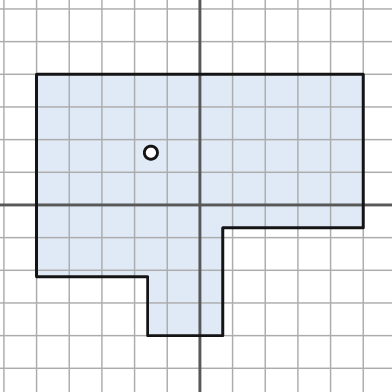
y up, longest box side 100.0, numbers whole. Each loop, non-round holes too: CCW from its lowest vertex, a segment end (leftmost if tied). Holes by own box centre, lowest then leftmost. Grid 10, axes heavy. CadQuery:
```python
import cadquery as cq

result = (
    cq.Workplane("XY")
    .moveTo(-16.0, -40.0)
    .lineTo(7.0, -40.0)
    .lineTo(7.0, -7.0)
    .lineTo(50.0, -7.0)
    .lineTo(50.0, 40.0)
    .lineTo(-50.0, 40.0)
    .lineTo(-50.0, -22.0)
    .lineTo(-16.0, -22.0)
    .close()
    .moveTo(-15.0, 16.0)
    .circle(2.0)
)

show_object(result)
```